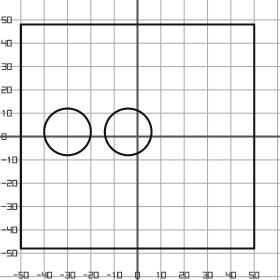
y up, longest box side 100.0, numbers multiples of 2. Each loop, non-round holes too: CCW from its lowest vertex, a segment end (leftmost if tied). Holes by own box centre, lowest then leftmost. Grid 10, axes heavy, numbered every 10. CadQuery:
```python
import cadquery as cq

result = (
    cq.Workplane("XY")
    .moveTo(-50.0, -48.0)
    .lineTo(50.0, -48.0)
    .lineTo(50.0, 48.0)
    .lineTo(-50.0, 48.0)
    .close()
    .moveTo(-30.0, 2.0)
    .circle(10.0)
    .moveTo(-4.0, 2.0)
    .circle(10.0)
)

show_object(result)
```